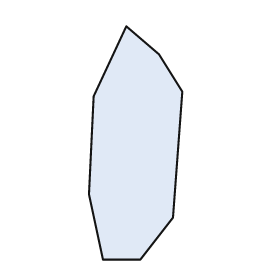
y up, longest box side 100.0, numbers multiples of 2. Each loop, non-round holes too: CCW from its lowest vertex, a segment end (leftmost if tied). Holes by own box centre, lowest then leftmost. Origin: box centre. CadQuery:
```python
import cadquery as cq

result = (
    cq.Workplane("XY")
    .moveTo(-14.0, -50.0)
    .lineTo(2.0, -50.0)
    .lineTo(16.0, -32.0)
    .lineTo(20.0, 22.0)
    .lineTo(10.0, 38.0)
    .lineTo(-4.0, 50.0)
    .lineTo(-18.0, 20.0)
    .lineTo(-20.0, -22.0)
    .close()
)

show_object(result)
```